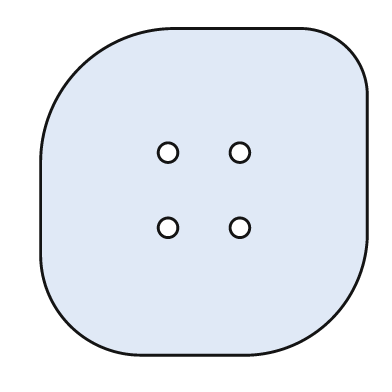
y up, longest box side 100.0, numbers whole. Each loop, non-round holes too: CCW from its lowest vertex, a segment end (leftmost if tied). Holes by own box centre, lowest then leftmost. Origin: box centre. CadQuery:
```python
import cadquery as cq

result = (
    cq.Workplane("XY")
    .moveTo(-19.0, -50.0)
    .lineTo(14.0, -50.0)
    .threePointArc((39.0, -39.0), (50.0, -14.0))
    .lineTo(50.0, 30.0)
    .threePointArc((44.0, 44.0), (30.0, 50.0))
    .lineTo(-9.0, 50.0)
    .threePointArc((-38.0, 38.0), (-50.0, 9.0))
    .lineTo(-50.0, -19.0)
    .threePointArc((-41.0, -41.0), (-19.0, -50.0))
    .close()
    .moveTo(-11.0, -11.0)
    .circle(3.0)
    .moveTo(11.0, -11.0)
    .circle(3.0)
    .moveTo(-11.0, 12.0)
    .circle(3.0)
    .moveTo(11.0, 12.0)
    .circle(3.0)
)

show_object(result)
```